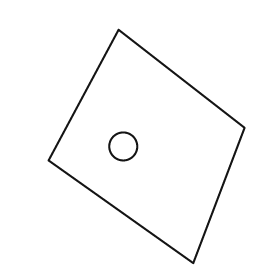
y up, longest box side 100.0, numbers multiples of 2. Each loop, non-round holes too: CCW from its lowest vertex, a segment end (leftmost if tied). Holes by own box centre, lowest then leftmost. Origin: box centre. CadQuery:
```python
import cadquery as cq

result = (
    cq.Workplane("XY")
    .moveTo(20.0, -50.0)
    .lineTo(42.0, 8.0)
    .lineTo(-12.0, 50.0)
    .lineTo(-42.0, -6.0)
    .close()
    .moveTo(-10.0, 0.0)
    .circle(6.0)
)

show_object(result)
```